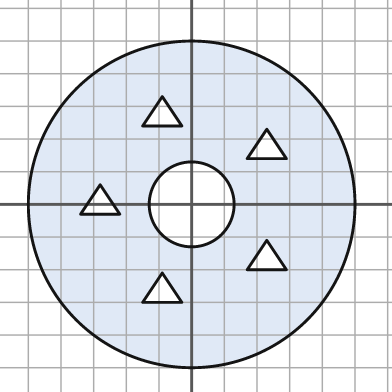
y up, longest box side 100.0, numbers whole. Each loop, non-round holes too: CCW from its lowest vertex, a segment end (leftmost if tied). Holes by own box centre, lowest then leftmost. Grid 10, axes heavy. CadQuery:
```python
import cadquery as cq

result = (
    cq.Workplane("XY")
    .moveTo(0.0, 0.0)
    .circle(50.0)
    .moveTo(-15.0, -30.0)
    .lineTo(-3.0, -30.0)
    .lineTo(-9.0, -21.0)
    .close()
    .moveTo(17.0, -20.0)
    .lineTo(29.0, -20.0)
    .lineTo(23.0, -11.0)
    .close()
    .moveTo(0.0, 0.0)
    .circle(13.0)
    .moveTo(-34.0, -3.0)
    .lineTo(-22.0, -3.0)
    .lineTo(-28.0, 6.0)
    .close()
    .moveTo(17.0, 14.0)
    .lineTo(29.0, 14.0)
    .lineTo(23.0, 23.0)
    .close()
    .moveTo(-15.0, 24.0)
    .lineTo(-3.0, 24.0)
    .lineTo(-9.0, 33.0)
    .close()
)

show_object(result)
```